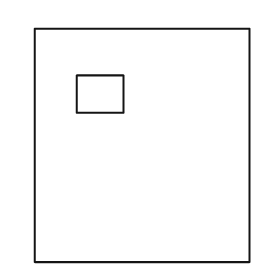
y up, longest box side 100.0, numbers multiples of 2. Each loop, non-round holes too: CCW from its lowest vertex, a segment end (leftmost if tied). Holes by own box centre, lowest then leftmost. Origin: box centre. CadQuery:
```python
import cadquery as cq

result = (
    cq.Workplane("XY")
    .moveTo(-46.0, -50.0)
    .lineTo(46.0, -50.0)
    .lineTo(46.0, 50.0)
    .lineTo(-46.0, 50.0)
    .close()
    .moveTo(-28.0, 14.0)
    .lineTo(-8.0, 14.0)
    .lineTo(-8.0, 30.0)
    .lineTo(-28.0, 30.0)
    .close()
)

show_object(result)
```